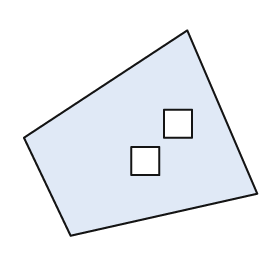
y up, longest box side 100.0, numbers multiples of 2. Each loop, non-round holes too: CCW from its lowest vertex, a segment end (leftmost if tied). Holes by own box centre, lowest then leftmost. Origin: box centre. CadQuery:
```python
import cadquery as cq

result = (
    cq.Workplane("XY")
    .moveTo(-30.0, -44.0)
    .lineTo(50.0, -26.0)
    .lineTo(20.0, 44.0)
    .lineTo(-50.0, -2.0)
    .close()
    .moveTo(-4.0, -18.0)
    .lineTo(8.0, -18.0)
    .lineTo(8.0, -6.0)
    .lineTo(-4.0, -6.0)
    .close()
    .moveTo(10.0, -2.0)
    .lineTo(22.0, -2.0)
    .lineTo(22.0, 10.0)
    .lineTo(10.0, 10.0)
    .close()
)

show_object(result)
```